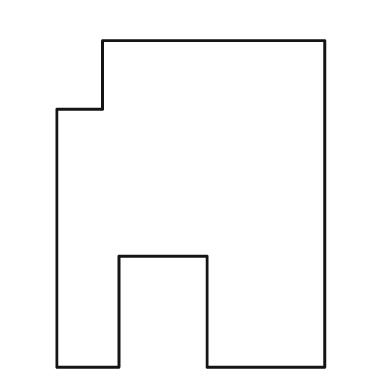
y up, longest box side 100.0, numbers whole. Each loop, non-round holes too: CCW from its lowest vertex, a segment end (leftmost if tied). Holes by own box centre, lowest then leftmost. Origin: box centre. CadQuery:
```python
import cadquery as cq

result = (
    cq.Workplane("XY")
    .moveTo(-41.0, -50.0)
    .lineTo(-22.0, -50.0)
    .lineTo(-22.0, -16.0)
    .lineTo(5.0, -16.0)
    .lineTo(5.0, -50.0)
    .lineTo(41.0, -50.0)
    .lineTo(41.0, 50.0)
    .lineTo(-27.0, 50.0)
    .lineTo(-27.0, 29.0)
    .lineTo(-41.0, 29.0)
    .close()
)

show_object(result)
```